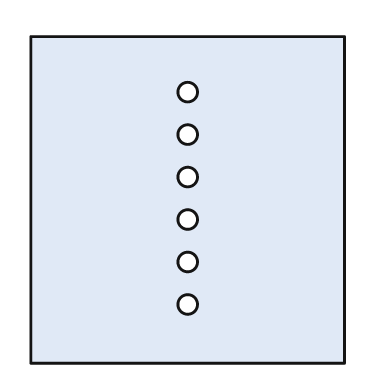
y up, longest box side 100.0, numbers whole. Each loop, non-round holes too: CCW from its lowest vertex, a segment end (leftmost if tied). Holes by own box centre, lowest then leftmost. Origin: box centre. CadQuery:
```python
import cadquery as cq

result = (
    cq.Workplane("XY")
    .moveTo(-48.0, -50.0)
    .lineTo(48.0, -50.0)
    .lineTo(48.0, 50.0)
    .lineTo(-48.0, 50.0)
    .close()
    .moveTo(0.0, -32.0)
    .circle(3.0)
    .moveTo(0.0, -19.0)
    .circle(3.0)
    .moveTo(0.0, -6.0)
    .circle(3.0)
    .moveTo(0.0, 7.0)
    .circle(3.0)
    .moveTo(0.0, 20.0)
    .circle(3.0)
    .moveTo(0.0, 33.0)
    .circle(3.0)
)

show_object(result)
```